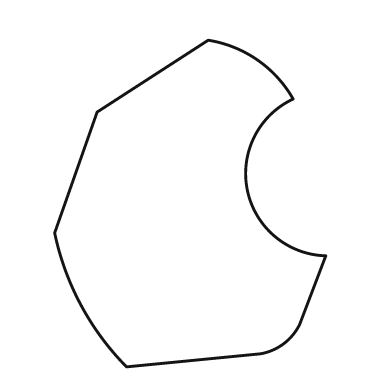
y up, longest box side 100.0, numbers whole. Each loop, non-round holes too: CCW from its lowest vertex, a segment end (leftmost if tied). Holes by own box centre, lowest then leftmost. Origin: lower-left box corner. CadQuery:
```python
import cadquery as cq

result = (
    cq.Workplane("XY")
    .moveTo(22.0, 0.0)
    .lineTo(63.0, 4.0)
    .threePointArc((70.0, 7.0), (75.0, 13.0))
    .lineTo(83.0, 34.0)
    .threePointArc((59.0, 54.0), (73.0, 82.0))
    .threePointArc((62.0, 94.0), (47.0, 100.0))
    .lineTo(13.0, 78.0)
    .lineTo(0.0, 41.0)
    .threePointArc((8.0, 19.0), (22.0, 0.0))
    .close()
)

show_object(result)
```